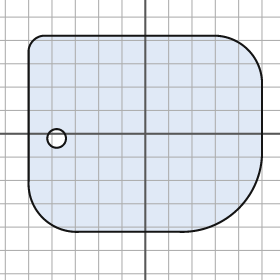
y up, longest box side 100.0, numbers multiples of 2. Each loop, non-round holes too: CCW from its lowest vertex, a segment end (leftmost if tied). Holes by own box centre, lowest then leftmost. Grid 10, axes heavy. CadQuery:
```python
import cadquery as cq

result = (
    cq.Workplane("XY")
    .moveTo(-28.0, -42.0)
    .lineTo(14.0, -42.0)
    .threePointArc((40.0, -32.0), (50.0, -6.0))
    .lineTo(50.0, 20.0)
    .threePointArc((44.0, 36.0), (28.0, 42.0))
    .lineTo(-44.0, 42.0)
    .threePointArc((-48.0, 40.0), (-50.0, 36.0))
    .lineTo(-50.0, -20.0)
    .threePointArc((-44.0, -36.0), (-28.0, -42.0))
    .close()
    .moveTo(-38.0, -2.0)
    .circle(4.0)
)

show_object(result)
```